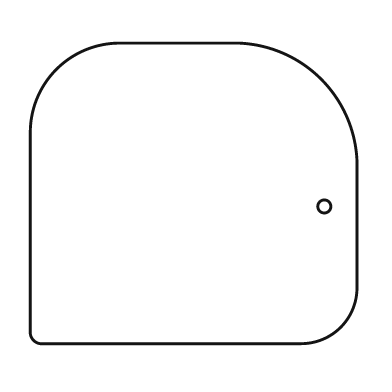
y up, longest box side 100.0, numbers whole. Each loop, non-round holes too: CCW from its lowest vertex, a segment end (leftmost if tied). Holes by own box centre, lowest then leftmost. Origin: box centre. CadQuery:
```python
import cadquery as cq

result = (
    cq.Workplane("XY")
    .moveTo(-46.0, -46.0)
    .lineTo(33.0, -46.0)
    .threePointArc((45.0, -41.0), (50.0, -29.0))
    .lineTo(50.0, 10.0)
    .threePointArc((39.0, 35.0), (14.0, 46.0))
    .lineTo(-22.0, 46.0)
    .threePointArc((-42.0, 38.0), (-50.0, 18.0))
    .lineTo(-50.0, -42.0)
    .threePointArc((-49.0, -45.0), (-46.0, -46.0))
    .close()
    .moveTo(40.0, -4.0)
    .circle(2.0)
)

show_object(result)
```